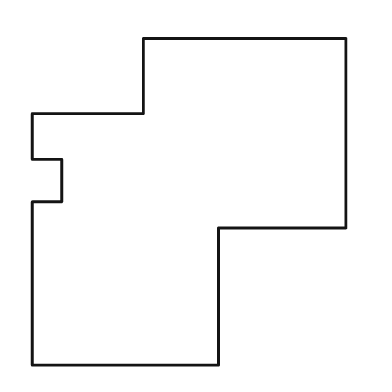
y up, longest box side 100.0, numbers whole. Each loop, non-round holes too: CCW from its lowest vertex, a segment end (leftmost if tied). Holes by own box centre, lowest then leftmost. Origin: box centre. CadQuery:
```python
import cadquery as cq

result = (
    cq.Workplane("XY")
    .moveTo(-48.0, -50.0)
    .lineTo(9.0, -50.0)
    .lineTo(9.0, -8.0)
    .lineTo(48.0, -8.0)
    .lineTo(48.0, 50.0)
    .lineTo(-14.0, 50.0)
    .lineTo(-14.0, 27.0)
    .lineTo(-48.0, 27.0)
    .lineTo(-48.0, 13.0)
    .lineTo(-39.0, 13.0)
    .lineTo(-39.0, 0.0)
    .lineTo(-48.0, 0.0)
    .close()
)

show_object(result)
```